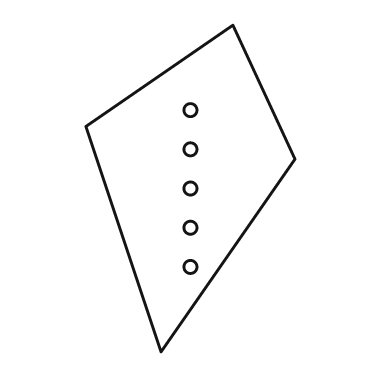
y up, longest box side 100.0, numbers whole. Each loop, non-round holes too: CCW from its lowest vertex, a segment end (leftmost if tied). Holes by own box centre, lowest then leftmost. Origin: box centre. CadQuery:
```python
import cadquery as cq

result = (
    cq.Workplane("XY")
    .moveTo(-9.0, -50.0)
    .lineTo(32.0, 9.0)
    .lineTo(13.0, 50.0)
    .lineTo(-32.0, 19.0)
    .close()
    .moveTo(0.0, -24.0)
    .circle(2.0)
    .moveTo(0.0, -12.0)
    .circle(2.0)
    .moveTo(0.0, 0.0)
    .circle(2.0)
    .moveTo(0.0, 12.0)
    .circle(2.0)
    .moveTo(0.0, 24.0)
    .circle(2.0)
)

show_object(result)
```